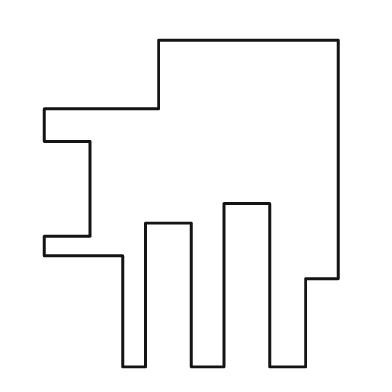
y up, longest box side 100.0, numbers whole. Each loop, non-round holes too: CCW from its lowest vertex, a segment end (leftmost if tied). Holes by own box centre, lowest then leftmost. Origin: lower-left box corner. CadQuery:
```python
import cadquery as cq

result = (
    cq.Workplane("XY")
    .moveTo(24.0, 0.0)
    .lineTo(31.0, 0.0)
    .lineTo(31.0, 44.0)
    .lineTo(45.0, 44.0)
    .lineTo(45.0, 0.0)
    .lineTo(55.0, 0.0)
    .lineTo(55.0, 50.0)
    .lineTo(69.0, 50.0)
    .lineTo(69.0, 0.0)
    .lineTo(80.0, 0.0)
    .lineTo(80.0, 27.0)
    .lineTo(90.0, 27.0)
    .lineTo(90.0, 100.0)
    .lineTo(35.0, 100.0)
    .lineTo(35.0, 79.0)
    .lineTo(0.0, 79.0)
    .lineTo(0.0, 69.0)
    .lineTo(14.0, 69.0)
    .lineTo(14.0, 40.0)
    .lineTo(0.0, 40.0)
    .lineTo(0.0, 34.0)
    .lineTo(24.0, 34.0)
    .close()
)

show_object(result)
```